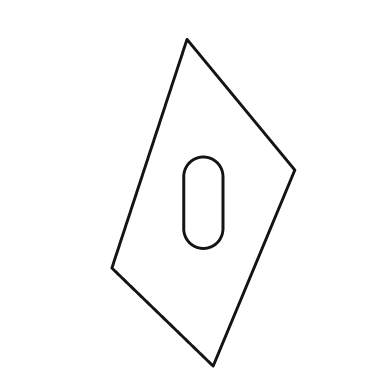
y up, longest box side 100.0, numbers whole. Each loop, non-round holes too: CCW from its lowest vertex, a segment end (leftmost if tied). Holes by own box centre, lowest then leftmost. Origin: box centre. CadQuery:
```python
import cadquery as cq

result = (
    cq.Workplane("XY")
    .moveTo(3.0, -50.0)
    .lineTo(28.0, 10.0)
    .lineTo(-5.0, 50.0)
    .lineTo(-28.0, -20.0)
    .close()
    .moveTo(-6.0, -8.0)
    .threePointArc((0.0, -14.0), (6.0, -8.0))
    .lineTo(6.0, 8.0)
    .threePointArc((0.0, 14.0), (-6.0, 8.0))
    .close()
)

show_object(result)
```